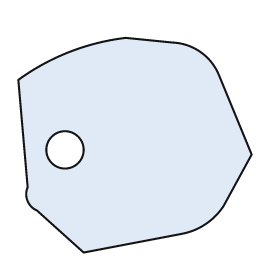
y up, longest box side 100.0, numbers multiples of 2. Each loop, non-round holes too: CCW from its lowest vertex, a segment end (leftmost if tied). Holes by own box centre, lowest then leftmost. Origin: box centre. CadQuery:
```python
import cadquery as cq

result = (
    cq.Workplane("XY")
    .moveTo(-22.0, -46.0)
    .lineTo(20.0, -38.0)
    .threePointArc((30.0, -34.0), (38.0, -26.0))
    .lineTo(50.0, -4.0)
    .lineTo(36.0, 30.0)
    .threePointArc((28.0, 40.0), (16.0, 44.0))
    .lineTo(-4.0, 46.0)
    .threePointArc((-28.0, 40.0), (-50.0, 28.0))
    .lineTo(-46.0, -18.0)
    .threePointArc((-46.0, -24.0), (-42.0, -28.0))
    .close()
    .moveTo(-30.0, -2.0)
    .circle(8.0)
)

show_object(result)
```